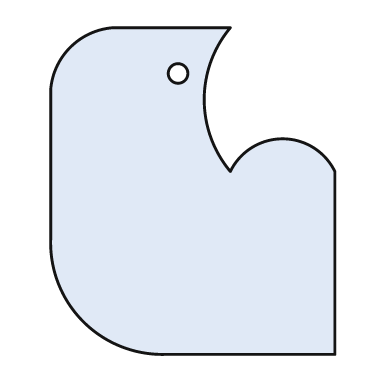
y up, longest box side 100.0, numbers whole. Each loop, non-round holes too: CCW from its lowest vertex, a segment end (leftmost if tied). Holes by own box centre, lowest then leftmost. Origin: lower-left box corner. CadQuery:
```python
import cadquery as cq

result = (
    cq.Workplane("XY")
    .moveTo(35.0, 0.0)
    .lineTo(87.0, 0.0)
    .lineTo(87.0, 56.0)
    .threePointArc((71.0, 66.0), (55.0, 56.0))
    .threePointArc((47.0, 78.0), (55.0, 100.0))
    .lineTo(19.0, 100.0)
    .threePointArc((6.0, 94.0), (0.0, 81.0))
    .lineTo(0.0, 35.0)
    .threePointArc((10.0, 10.0), (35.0, 0.0))
    .close()
    .moveTo(39.0, 86.0)
    .circle(3.0)
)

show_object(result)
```